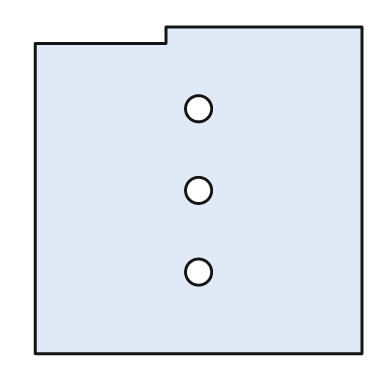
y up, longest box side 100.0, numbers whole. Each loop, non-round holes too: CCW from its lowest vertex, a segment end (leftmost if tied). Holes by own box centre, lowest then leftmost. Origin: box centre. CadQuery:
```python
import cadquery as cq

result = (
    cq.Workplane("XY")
    .moveTo(-50.0, -50.0)
    .lineTo(50.0, -50.0)
    .lineTo(50.0, 50.0)
    .lineTo(-10.0, 50.0)
    .lineTo(-10.0, 45.0)
    .lineTo(-50.0, 45.0)
    .close()
    .moveTo(0.0, -25.0)
    .circle(4.0)
    .moveTo(0.0, 0.0)
    .circle(4.0)
    .moveTo(0.0, 25.0)
    .circle(4.0)
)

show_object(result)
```